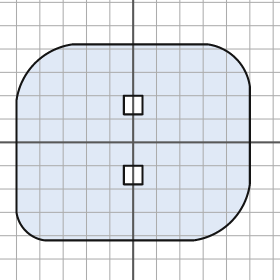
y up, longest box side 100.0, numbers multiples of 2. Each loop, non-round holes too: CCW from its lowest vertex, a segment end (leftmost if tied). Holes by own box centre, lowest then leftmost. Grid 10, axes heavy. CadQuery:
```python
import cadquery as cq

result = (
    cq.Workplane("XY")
    .moveTo(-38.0, -42.0)
    .lineTo(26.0, -42.0)
    .threePointArc((42.0, -34.0), (50.0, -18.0))
    .lineTo(50.0, 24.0)
    .threePointArc((44.0, 36.0), (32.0, 42.0))
    .lineTo(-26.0, 42.0)
    .threePointArc((-42.0, 34.0), (-50.0, 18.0))
    .lineTo(-50.0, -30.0)
    .threePointArc((-46.0, -38.0), (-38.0, -42.0))
    .close()
    .moveTo(-4.0, -18.0)
    .lineTo(4.0, -18.0)
    .lineTo(4.0, -10.0)
    .lineTo(-4.0, -10.0)
    .close()
    .moveTo(-4.0, 12.0)
    .lineTo(4.0, 12.0)
    .lineTo(4.0, 20.0)
    .lineTo(-4.0, 20.0)
    .close()
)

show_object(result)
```